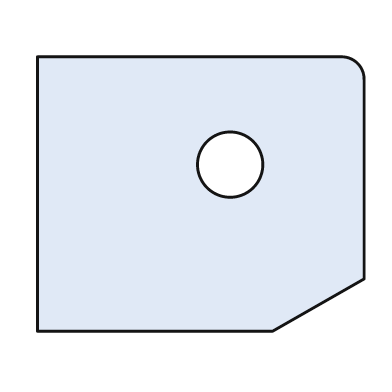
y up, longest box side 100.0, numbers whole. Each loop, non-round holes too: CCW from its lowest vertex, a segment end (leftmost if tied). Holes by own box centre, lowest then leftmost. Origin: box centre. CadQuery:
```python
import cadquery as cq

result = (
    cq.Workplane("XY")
    .moveTo(-50.0, -42.0)
    .lineTo(22.0, -42.0)
    .lineTo(50.0, -26.0)
    .lineTo(50.0, 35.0)
    .threePointArc((48.0, 40.0), (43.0, 42.0))
    .lineTo(-50.0, 42.0)
    .close()
    .moveTo(9.0, 9.0)
    .circle(10.0)
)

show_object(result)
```